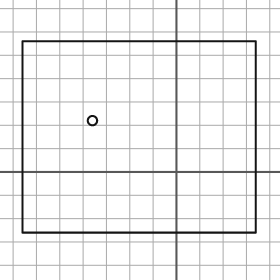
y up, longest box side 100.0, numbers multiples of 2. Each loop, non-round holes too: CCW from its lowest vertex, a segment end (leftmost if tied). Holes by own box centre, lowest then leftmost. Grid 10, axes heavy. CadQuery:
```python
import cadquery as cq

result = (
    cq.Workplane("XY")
    .moveTo(-66.0, -26.0)
    .lineTo(34.0, -26.0)
    .lineTo(34.0, 56.0)
    .lineTo(-66.0, 56.0)
    .close()
    .moveTo(-36.0, 22.0)
    .circle(2.0)
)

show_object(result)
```